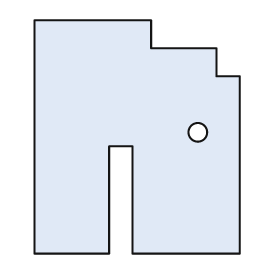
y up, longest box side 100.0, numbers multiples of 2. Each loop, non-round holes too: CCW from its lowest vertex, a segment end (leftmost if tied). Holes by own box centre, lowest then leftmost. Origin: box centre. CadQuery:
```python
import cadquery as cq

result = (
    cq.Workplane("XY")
    .moveTo(-44.0, -50.0)
    .lineTo(-12.0, -50.0)
    .lineTo(-12.0, -4.0)
    .lineTo(-2.0, -4.0)
    .lineTo(-2.0, -50.0)
    .lineTo(44.0, -50.0)
    .lineTo(44.0, 26.0)
    .lineTo(34.0, 26.0)
    .lineTo(34.0, 38.0)
    .lineTo(6.0, 38.0)
    .lineTo(6.0, 50.0)
    .lineTo(-44.0, 50.0)
    .close()
    .moveTo(26.0, 2.0)
    .circle(4.0)
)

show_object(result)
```